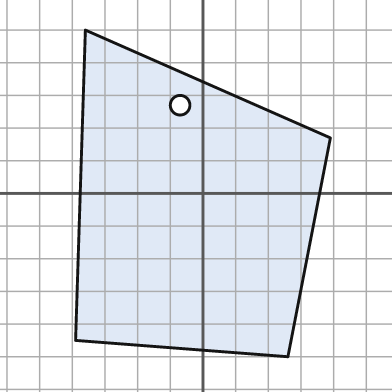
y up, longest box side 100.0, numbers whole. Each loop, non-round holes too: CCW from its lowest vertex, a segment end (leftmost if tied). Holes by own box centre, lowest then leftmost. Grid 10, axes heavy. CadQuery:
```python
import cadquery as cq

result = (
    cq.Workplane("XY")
    .moveTo(26.0, -50.0)
    .lineTo(39.0, 17.0)
    .lineTo(-36.0, 50.0)
    .lineTo(-39.0, -45.0)
    .close()
    .moveTo(-7.0, 27.0)
    .circle(3.0)
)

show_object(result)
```